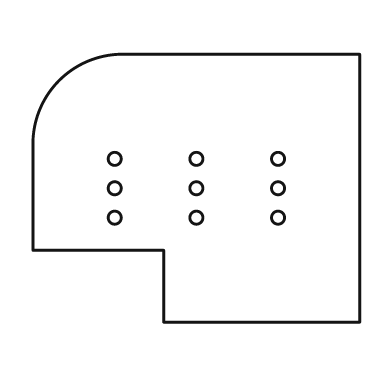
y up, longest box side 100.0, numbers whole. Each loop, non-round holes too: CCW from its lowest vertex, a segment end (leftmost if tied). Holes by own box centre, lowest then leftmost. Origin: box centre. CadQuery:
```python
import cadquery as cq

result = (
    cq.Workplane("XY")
    .moveTo(-10.0, -41.0)
    .lineTo(50.0, -41.0)
    .lineTo(50.0, 41.0)
    .lineTo(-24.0, 41.0)
    .threePointArc((-42.0, 33.0), (-50.0, 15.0))
    .lineTo(-50.0, -19.0)
    .lineTo(-10.0, -19.0)
    .close()
    .moveTo(-25.0, -9.0)
    .circle(2.0)
    .moveTo(0.0, -9.0)
    .circle(2.0)
    .moveTo(25.0, -9.0)
    .circle(2.0)
    .moveTo(-25.0, 0.0)
    .circle(2.0)
    .moveTo(0.0, 0.0)
    .circle(2.0)
    .moveTo(25.0, 0.0)
    .circle(2.0)
    .moveTo(-25.0, 9.0)
    .circle(2.0)
    .moveTo(0.0, 9.0)
    .circle(2.0)
    .moveTo(25.0, 9.0)
    .circle(2.0)
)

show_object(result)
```